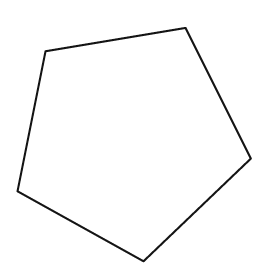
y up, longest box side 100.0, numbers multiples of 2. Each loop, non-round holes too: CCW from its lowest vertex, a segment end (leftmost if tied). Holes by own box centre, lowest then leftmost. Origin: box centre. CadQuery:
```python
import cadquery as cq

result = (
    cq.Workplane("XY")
    .moveTo(4.0, -50.0)
    .lineTo(50.0, -6.0)
    .lineTo(22.0, 50.0)
    .lineTo(-38.0, 40.0)
    .lineTo(-50.0, -20.0)
    .close()
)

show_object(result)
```